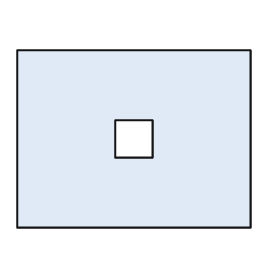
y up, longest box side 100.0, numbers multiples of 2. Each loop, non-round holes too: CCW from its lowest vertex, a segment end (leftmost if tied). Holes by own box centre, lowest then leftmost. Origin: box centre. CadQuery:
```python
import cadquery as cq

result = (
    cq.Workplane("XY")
    .moveTo(-50.0, -38.0)
    .lineTo(50.0, -38.0)
    .lineTo(50.0, 38.0)
    .lineTo(-50.0, 38.0)
    .close()
    .moveTo(-8.0, -8.0)
    .lineTo(8.0, -8.0)
    .lineTo(8.0, 8.0)
    .lineTo(-8.0, 8.0)
    .close()
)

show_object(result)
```